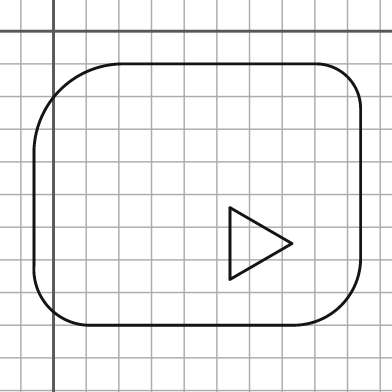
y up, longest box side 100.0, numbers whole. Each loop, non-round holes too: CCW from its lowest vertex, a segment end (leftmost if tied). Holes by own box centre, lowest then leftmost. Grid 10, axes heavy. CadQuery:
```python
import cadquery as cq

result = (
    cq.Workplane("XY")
    .moveTo(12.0, -90.0)
    .lineTo(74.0, -90.0)
    .threePointArc((88.0, -84.0), (94.0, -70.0))
    .lineTo(94.0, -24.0)
    .threePointArc((90.0, -14.0), (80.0, -10.0))
    .lineTo(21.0, -10.0)
    .threePointArc((2.0, -18.0), (-6.0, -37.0))
    .lineTo(-6.0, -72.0)
    .threePointArc((-1.0, -85.0), (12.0, -90.0))
    .close()
    .moveTo(54.0, -76.0)
    .lineTo(73.0, -65.0)
    .lineTo(54.0, -54.0)
    .close()
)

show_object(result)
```